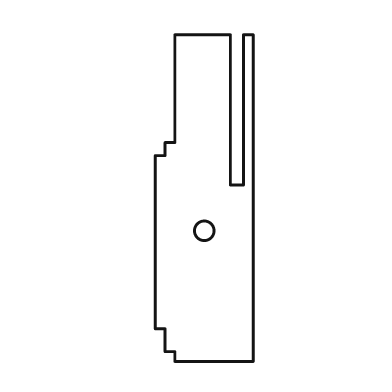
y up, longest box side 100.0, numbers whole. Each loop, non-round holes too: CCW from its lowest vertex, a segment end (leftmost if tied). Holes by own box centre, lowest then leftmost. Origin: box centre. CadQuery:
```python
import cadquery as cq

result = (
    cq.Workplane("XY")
    .moveTo(-9.0, -50.0)
    .lineTo(15.0, -50.0)
    .lineTo(15.0, 50.0)
    .lineTo(12.0, 50.0)
    .lineTo(12.0, 4.0)
    .lineTo(8.0, 4.0)
    .lineTo(8.0, 50.0)
    .lineTo(-9.0, 50.0)
    .lineTo(-9.0, 17.0)
    .lineTo(-12.0, 17.0)
    .lineTo(-12.0, 13.0)
    .lineTo(-15.0, 13.0)
    .lineTo(-15.0, -40.0)
    .lineTo(-12.0, -40.0)
    .lineTo(-12.0, -47.0)
    .lineTo(-9.0, -47.0)
    .close()
    .moveTo(0.0, -10.0)
    .circle(3.0)
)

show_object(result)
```